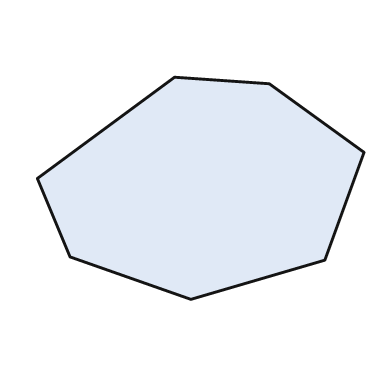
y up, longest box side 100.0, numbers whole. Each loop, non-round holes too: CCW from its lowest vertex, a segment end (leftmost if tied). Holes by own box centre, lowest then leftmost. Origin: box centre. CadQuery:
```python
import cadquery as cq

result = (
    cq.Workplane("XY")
    .moveTo(-3.0, -34.0)
    .lineTo(38.0, -22.0)
    .lineTo(50.0, 11.0)
    .lineTo(21.0, 32.0)
    .lineTo(-8.0, 34.0)
    .lineTo(-50.0, 3.0)
    .lineTo(-40.0, -21.0)
    .close()
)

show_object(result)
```